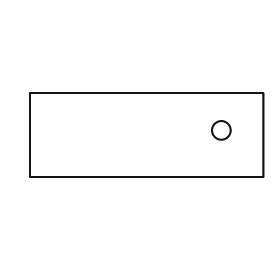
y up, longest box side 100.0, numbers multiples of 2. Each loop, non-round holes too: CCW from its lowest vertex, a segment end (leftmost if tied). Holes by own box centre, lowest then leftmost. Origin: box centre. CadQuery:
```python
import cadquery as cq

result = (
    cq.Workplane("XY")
    .moveTo(-50.0, -18.0)
    .lineTo(50.0, -18.0)
    .lineTo(50.0, 18.0)
    .lineTo(-50.0, 18.0)
    .close()
    .moveTo(32.0, 2.0)
    .circle(4.0)
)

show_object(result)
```